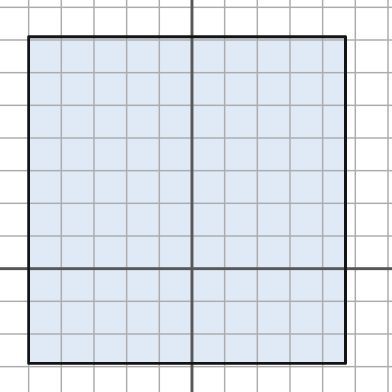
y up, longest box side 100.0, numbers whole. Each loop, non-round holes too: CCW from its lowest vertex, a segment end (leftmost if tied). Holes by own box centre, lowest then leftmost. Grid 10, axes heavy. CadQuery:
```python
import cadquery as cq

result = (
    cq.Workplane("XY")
    .moveTo(-50.0, -29.0)
    .lineTo(47.0, -29.0)
    .lineTo(47.0, 71.0)
    .lineTo(-50.0, 71.0)
    .close()
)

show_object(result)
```